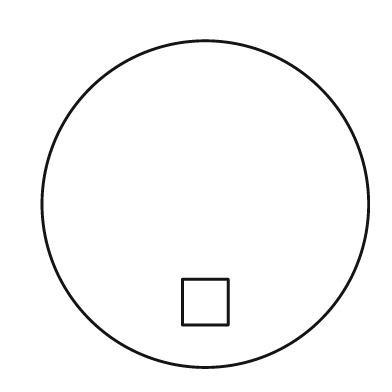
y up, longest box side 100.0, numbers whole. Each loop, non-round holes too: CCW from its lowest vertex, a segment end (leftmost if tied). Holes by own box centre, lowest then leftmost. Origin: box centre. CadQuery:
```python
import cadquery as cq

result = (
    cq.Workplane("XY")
    .moveTo(0.0, 0.0)
    .circle(50.0)
    .moveTo(-7.0, -37.0)
    .lineTo(7.0, -37.0)
    .lineTo(7.0, -23.0)
    .lineTo(-7.0, -23.0)
    .close()
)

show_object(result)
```